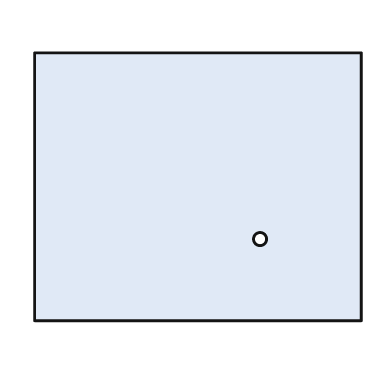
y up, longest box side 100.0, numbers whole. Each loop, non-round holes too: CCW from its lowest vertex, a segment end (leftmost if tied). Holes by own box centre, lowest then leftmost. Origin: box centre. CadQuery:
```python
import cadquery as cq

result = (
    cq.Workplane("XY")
    .moveTo(-50.0, -41.0)
    .lineTo(50.0, -41.0)
    .lineTo(50.0, 41.0)
    .lineTo(-50.0, 41.0)
    .close()
    .moveTo(19.0, -16.0)
    .circle(2.0)
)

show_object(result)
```